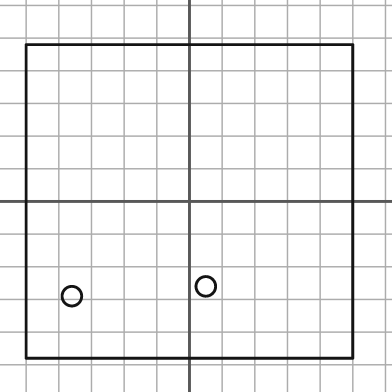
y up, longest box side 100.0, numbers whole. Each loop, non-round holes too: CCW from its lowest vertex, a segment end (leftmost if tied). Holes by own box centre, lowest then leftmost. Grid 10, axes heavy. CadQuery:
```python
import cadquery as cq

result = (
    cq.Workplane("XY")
    .moveTo(-50.0, -48.0)
    .lineTo(50.0, -48.0)
    .lineTo(50.0, 48.0)
    .lineTo(-50.0, 48.0)
    .close()
    .moveTo(-36.0, -29.0)
    .circle(3.0)
    .moveTo(5.0, -26.0)
    .circle(3.0)
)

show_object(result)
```